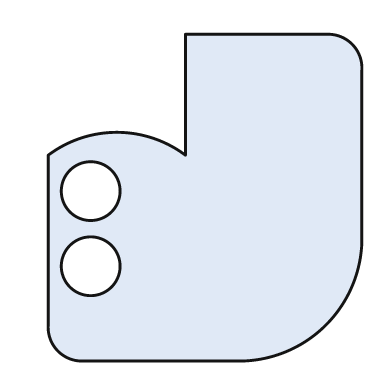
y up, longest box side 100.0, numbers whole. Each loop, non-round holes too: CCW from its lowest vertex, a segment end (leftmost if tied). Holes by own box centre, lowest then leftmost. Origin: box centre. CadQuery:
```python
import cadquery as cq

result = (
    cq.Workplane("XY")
    .moveTo(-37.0, -50.0)
    .lineTo(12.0, -50.0)
    .threePointArc((37.0, -39.0), (48.0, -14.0))
    .lineTo(48.0, 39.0)
    .threePointArc((45.0, 47.0), (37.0, 50.0))
    .lineTo(-6.0, 50.0)
    .lineTo(-6.0, 13.0)
    .threePointArc((-27.0, 20.0), (-48.0, 13.0))
    .lineTo(-48.0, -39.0)
    .threePointArc((-45.0, -47.0), (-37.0, -50.0))
    .close()
    .moveTo(-35.0, -21.0)
    .circle(9.0)
    .moveTo(-35.0, 2.0)
    .circle(9.0)
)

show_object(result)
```